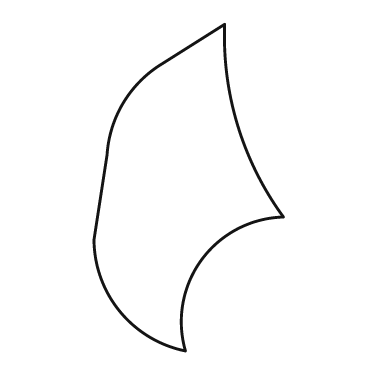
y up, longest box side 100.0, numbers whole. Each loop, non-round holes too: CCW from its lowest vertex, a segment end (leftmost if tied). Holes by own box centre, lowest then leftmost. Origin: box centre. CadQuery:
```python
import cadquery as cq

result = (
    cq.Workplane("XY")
    .moveTo(-1.0, -50.0)
    .threePointArc((4.0, -22.0), (29.0, -9.0))
    .threePointArc((15.0, 19.0), (11.0, 50.0))
    .lineTo(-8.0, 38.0)
    .threePointArc((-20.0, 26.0), (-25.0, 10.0))
    .lineTo(-29.0, -16.0)
    .threePointArc((-21.0, -38.0), (-1.0, -50.0))
    .close()
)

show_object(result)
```